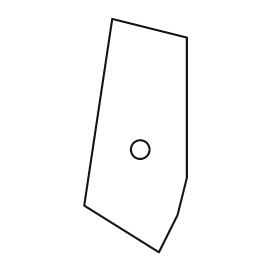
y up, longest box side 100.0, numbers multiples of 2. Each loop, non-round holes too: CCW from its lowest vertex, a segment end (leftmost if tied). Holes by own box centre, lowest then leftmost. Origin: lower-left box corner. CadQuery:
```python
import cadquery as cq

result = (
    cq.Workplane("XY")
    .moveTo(32.0, 0.0)
    .lineTo(40.0, 16.0)
    .lineTo(44.0, 32.0)
    .lineTo(44.0, 92.0)
    .lineTo(12.0, 100.0)
    .lineTo(0.0, 20.0)
    .close()
    .moveTo(24.0, 44.0)
    .circle(4.0)
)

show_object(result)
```